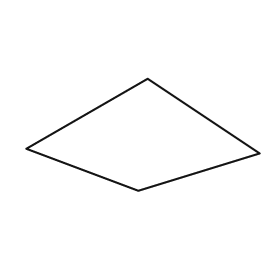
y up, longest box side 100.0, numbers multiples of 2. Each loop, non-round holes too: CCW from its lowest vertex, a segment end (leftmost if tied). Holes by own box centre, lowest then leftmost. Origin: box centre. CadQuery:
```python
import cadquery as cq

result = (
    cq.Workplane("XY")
    .moveTo(-2.0, -24.0)
    .lineTo(50.0, -8.0)
    .lineTo(2.0, 24.0)
    .lineTo(-50.0, -6.0)
    .close()
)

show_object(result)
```